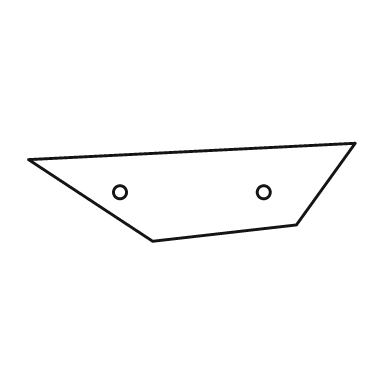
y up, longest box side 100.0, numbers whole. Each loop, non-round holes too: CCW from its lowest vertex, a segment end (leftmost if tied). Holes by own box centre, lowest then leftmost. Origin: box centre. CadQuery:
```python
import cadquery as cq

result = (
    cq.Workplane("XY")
    .moveTo(-12.0, -15.0)
    .lineTo(32.0, -10.0)
    .lineTo(50.0, 15.0)
    .lineTo(-50.0, 10.0)
    .close()
    .moveTo(-22.0, 0.0)
    .circle(2.0)
    .moveTo(22.0, 0.0)
    .circle(2.0)
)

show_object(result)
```